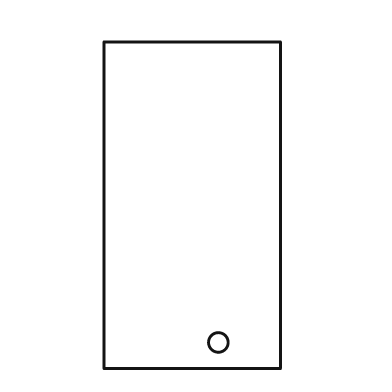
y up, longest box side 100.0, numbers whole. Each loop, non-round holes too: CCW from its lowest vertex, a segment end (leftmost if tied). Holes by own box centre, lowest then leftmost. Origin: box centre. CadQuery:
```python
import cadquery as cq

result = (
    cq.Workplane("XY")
    .moveTo(-27.0, -50.0)
    .lineTo(27.0, -50.0)
    .lineTo(27.0, 50.0)
    .lineTo(-27.0, 50.0)
    .close()
    .moveTo(8.0, -42.0)
    .circle(3.0)
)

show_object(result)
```